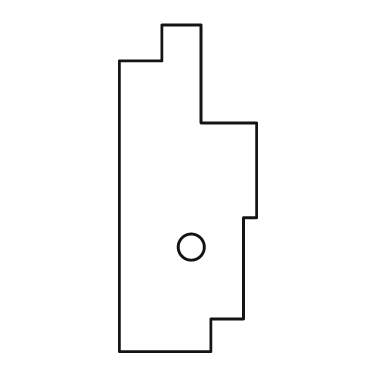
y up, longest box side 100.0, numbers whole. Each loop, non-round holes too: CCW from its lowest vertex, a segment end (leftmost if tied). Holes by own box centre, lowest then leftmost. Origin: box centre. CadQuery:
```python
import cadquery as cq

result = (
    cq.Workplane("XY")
    .moveTo(-21.0, -50.0)
    .lineTo(7.0, -50.0)
    .lineTo(7.0, -40.0)
    .lineTo(17.0, -40.0)
    .lineTo(17.0, -9.0)
    .lineTo(21.0, -9.0)
    .lineTo(21.0, 20.0)
    .lineTo(4.0, 20.0)
    .lineTo(4.0, 50.0)
    .lineTo(-8.0, 50.0)
    .lineTo(-8.0, 39.0)
    .lineTo(-21.0, 39.0)
    .close()
    .moveTo(1.0, -18.0)
    .circle(4.0)
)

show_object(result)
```